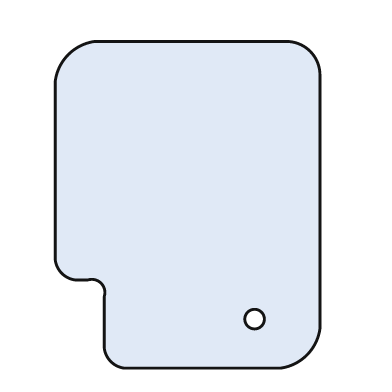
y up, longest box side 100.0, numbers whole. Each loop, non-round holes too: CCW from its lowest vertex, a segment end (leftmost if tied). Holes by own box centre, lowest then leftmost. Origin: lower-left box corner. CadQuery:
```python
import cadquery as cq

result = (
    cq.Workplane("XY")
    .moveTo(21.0, 0.0)
    .lineTo(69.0, 0.0)
    .threePointArc((77.0, 4.0), (81.0, 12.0))
    .lineTo(81.0, 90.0)
    .threePointArc((78.0, 97.0), (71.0, 100.0))
    .lineTo(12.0, 100.0)
    .threePointArc((4.0, 96.0), (0.0, 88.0))
    .lineTo(0.0, 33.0)
    .threePointArc((2.0, 29.0), (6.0, 27.0))
    .lineTo(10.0, 27.0)
    .threePointArc((14.0, 26.0), (15.0, 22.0))
    .lineTo(15.0, 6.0)
    .threePointArc((17.0, 2.0), (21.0, 0.0))
    .close()
    .moveTo(61.0, 15.0)
    .circle(3.0)
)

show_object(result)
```